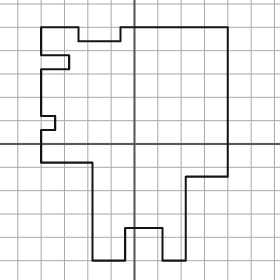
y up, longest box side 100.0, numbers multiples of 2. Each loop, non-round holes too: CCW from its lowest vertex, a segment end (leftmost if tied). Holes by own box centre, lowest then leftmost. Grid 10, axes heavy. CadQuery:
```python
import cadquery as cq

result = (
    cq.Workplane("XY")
    .moveTo(-18.0, -50.0)
    .lineTo(-4.0, -50.0)
    .lineTo(-4.0, -36.0)
    .lineTo(12.0, -36.0)
    .lineTo(12.0, -50.0)
    .lineTo(22.0, -50.0)
    .lineTo(22.0, -14.0)
    .lineTo(40.0, -14.0)
    .lineTo(40.0, 50.0)
    .lineTo(-6.0, 50.0)
    .lineTo(-6.0, 44.0)
    .lineTo(-24.0, 44.0)
    .lineTo(-24.0, 50.0)
    .lineTo(-40.0, 50.0)
    .lineTo(-40.0, 38.0)
    .lineTo(-28.0, 38.0)
    .lineTo(-28.0, 32.0)
    .lineTo(-40.0, 32.0)
    .lineTo(-40.0, 12.0)
    .lineTo(-34.0, 12.0)
    .lineTo(-34.0, 6.0)
    .lineTo(-40.0, 6.0)
    .lineTo(-40.0, -8.0)
    .lineTo(-18.0, -8.0)
    .close()
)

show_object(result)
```